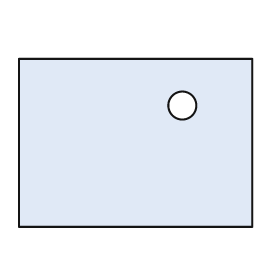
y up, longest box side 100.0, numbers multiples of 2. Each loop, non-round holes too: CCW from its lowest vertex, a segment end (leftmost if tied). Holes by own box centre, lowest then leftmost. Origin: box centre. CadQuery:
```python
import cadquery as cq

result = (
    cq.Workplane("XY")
    .moveTo(-50.0, -36.0)
    .lineTo(50.0, -36.0)
    .lineTo(50.0, 36.0)
    .lineTo(-50.0, 36.0)
    .close()
    .moveTo(20.0, 16.0)
    .circle(6.0)
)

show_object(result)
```